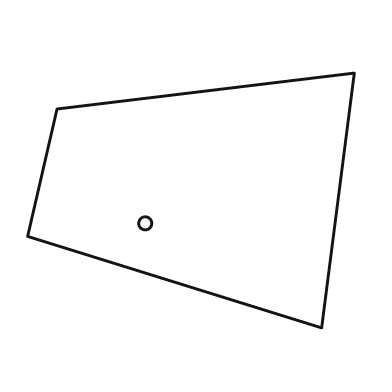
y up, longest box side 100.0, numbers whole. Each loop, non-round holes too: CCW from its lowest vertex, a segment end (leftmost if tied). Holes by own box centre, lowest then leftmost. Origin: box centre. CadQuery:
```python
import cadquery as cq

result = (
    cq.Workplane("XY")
    .moveTo(40.0, -39.0)
    .lineTo(50.0, 39.0)
    .lineTo(-41.0, 28.0)
    .lineTo(-50.0, -11.0)
    .close()
    .moveTo(-14.0, -7.0)
    .circle(2.0)
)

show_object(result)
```